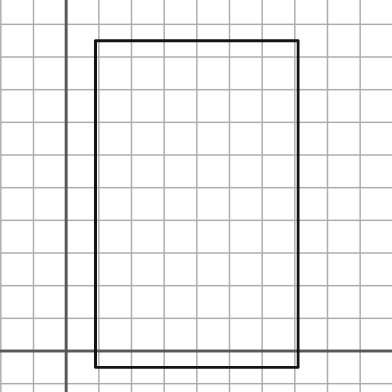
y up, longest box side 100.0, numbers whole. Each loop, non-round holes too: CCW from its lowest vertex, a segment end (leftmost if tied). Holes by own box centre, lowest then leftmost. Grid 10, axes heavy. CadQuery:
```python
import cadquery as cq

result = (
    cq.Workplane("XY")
    .moveTo(9.0, -5.0)
    .lineTo(71.0, -5.0)
    .lineTo(71.0, 95.0)
    .lineTo(9.0, 95.0)
    .close()
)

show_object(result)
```